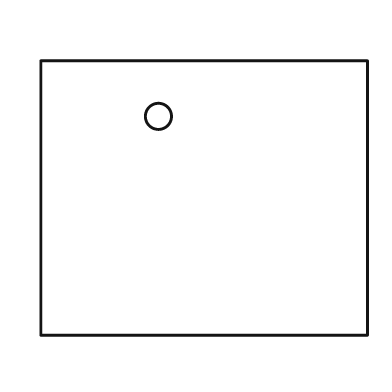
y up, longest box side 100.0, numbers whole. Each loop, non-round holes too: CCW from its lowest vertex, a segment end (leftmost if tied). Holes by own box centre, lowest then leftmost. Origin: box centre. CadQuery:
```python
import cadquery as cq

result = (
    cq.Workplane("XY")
    .moveTo(-50.0, -42.0)
    .lineTo(50.0, -42.0)
    .lineTo(50.0, 42.0)
    .lineTo(-50.0, 42.0)
    .close()
    .moveTo(-14.0, 25.0)
    .circle(4.0)
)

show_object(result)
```